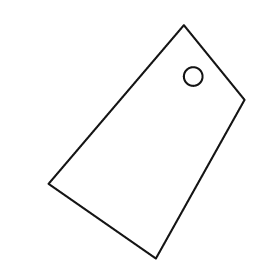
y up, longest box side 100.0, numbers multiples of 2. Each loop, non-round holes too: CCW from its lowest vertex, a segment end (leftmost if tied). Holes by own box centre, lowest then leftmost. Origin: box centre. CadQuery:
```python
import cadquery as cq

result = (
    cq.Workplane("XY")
    .moveTo(4.0, -50.0)
    .lineTo(42.0, 18.0)
    .lineTo(16.0, 50.0)
    .lineTo(-42.0, -18.0)
    .close()
    .moveTo(20.0, 28.0)
    .circle(4.0)
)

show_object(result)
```